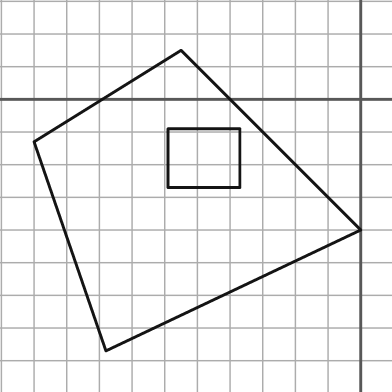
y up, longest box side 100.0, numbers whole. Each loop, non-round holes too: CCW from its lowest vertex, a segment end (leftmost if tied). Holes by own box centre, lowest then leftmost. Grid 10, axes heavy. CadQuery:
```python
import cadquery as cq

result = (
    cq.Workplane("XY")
    .moveTo(-78.0, -77.0)
    .lineTo(0.0, -40.0)
    .lineTo(-55.0, 15.0)
    .lineTo(-100.0, -13.0)
    .close()
    .moveTo(-59.0, -27.0)
    .lineTo(-37.0, -27.0)
    .lineTo(-37.0, -9.0)
    .lineTo(-59.0, -9.0)
    .close()
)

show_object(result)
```